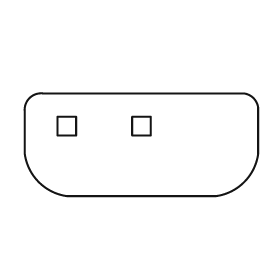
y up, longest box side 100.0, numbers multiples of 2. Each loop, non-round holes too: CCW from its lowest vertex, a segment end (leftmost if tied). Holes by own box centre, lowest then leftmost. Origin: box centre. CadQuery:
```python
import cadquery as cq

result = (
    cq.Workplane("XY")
    .moveTo(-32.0, -22.0)
    .lineTo(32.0, -22.0)
    .threePointArc((44.0, -16.0), (50.0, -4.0))
    .lineTo(50.0, 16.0)
    .threePointArc((48.0, 20.0), (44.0, 22.0))
    .lineTo(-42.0, 22.0)
    .threePointArc((-48.0, 20.0), (-50.0, 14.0))
    .lineTo(-50.0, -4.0)
    .threePointArc((-44.0, -16.0), (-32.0, -22.0))
    .close()
    .moveTo(-36.0, 4.0)
    .lineTo(-28.0, 4.0)
    .lineTo(-28.0, 12.0)
    .lineTo(-36.0, 12.0)
    .close()
    .moveTo(-4.0, 4.0)
    .lineTo(4.0, 4.0)
    .lineTo(4.0, 12.0)
    .lineTo(-4.0, 12.0)
    .close()
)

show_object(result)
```